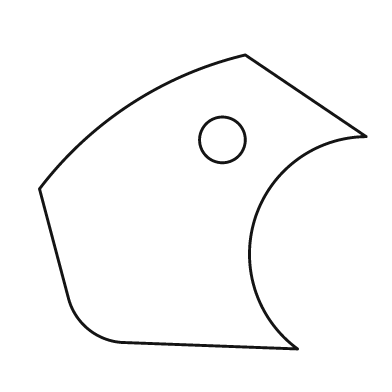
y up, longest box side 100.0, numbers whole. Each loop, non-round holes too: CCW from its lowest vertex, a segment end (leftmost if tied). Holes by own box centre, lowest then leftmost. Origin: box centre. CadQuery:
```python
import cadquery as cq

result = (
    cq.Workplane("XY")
    .moveTo(29.0, -45.0)
    .threePointArc((16.0, -5.0), (50.0, 20.0))
    .lineTo(13.0, 45.0)
    .threePointArc((-22.0, 30.0), (-50.0, 4.0))
    .lineTo(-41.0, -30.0)
    .threePointArc((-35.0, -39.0), (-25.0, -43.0))
    .close()
    .moveTo(6.0, 19.0)
    .circle(7.0)
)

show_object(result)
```